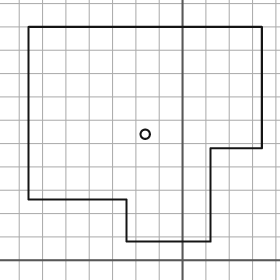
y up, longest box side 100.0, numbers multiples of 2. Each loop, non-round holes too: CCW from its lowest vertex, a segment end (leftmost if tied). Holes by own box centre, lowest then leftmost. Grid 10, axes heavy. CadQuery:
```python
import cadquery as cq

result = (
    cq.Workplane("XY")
    .moveTo(-24.0, 8.0)
    .lineTo(12.0, 8.0)
    .lineTo(12.0, 48.0)
    .lineTo(34.0, 48.0)
    .lineTo(34.0, 100.0)
    .lineTo(-66.0, 100.0)
    .lineTo(-66.0, 26.0)
    .lineTo(-24.0, 26.0)
    .close()
    .moveTo(-16.0, 54.0)
    .circle(2.0)
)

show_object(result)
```